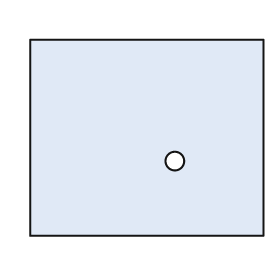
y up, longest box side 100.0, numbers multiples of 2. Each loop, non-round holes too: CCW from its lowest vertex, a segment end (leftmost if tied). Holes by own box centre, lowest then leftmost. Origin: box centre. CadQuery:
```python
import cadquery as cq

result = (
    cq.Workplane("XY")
    .moveTo(-50.0, -42.0)
    .lineTo(50.0, -42.0)
    .lineTo(50.0, 42.0)
    .lineTo(-50.0, 42.0)
    .close()
    .moveTo(12.0, -10.0)
    .circle(4.0)
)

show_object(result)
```